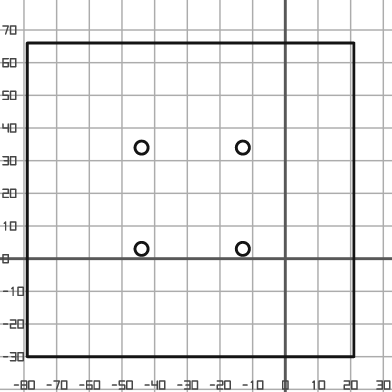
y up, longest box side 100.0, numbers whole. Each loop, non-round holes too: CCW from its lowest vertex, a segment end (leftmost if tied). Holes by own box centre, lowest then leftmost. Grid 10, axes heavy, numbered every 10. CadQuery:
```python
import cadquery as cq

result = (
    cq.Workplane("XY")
    .moveTo(-79.0, -30.0)
    .lineTo(21.0, -30.0)
    .lineTo(21.0, 66.0)
    .lineTo(-79.0, 66.0)
    .close()
    .moveTo(-44.0, 3.0)
    .circle(2.0)
    .moveTo(-13.0, 3.0)
    .circle(2.0)
    .moveTo(-44.0, 34.0)
    .circle(2.0)
    .moveTo(-13.0, 34.0)
    .circle(2.0)
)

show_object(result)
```